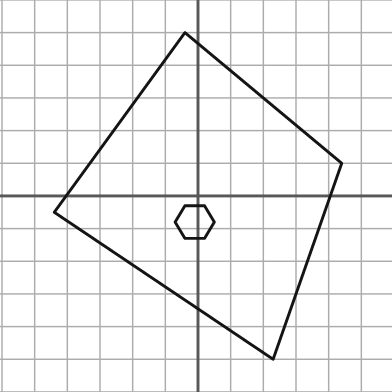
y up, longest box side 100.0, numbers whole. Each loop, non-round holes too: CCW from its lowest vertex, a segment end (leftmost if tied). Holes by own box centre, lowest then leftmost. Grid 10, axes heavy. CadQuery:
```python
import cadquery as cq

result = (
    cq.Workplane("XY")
    .moveTo(23.0, -50.0)
    .lineTo(44.0, 10.0)
    .lineTo(-4.0, 50.0)
    .lineTo(-44.0, -5.0)
    .close()
    .moveTo(-4.0, -13.0)
    .lineTo(2.0, -13.0)
    .lineTo(5.0, -8.0)
    .lineTo(2.0, -3.0)
    .lineTo(-4.0, -3.0)
    .lineTo(-7.0, -8.0)
    .close()
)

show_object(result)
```